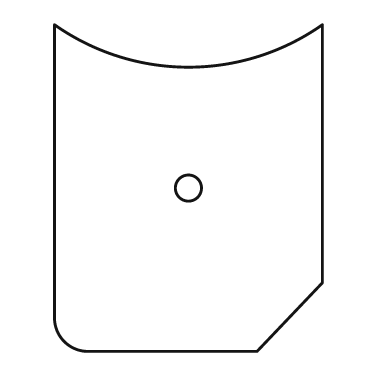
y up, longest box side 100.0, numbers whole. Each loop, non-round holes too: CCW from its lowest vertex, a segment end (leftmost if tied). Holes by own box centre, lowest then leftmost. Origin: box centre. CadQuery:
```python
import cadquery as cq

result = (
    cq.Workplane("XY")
    .moveTo(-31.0, -50.0)
    .lineTo(21.0, -50.0)
    .lineTo(41.0, -29.0)
    .lineTo(41.0, 50.0)
    .threePointArc((0.0, 37.0), (-41.0, 50.0))
    .lineTo(-41.0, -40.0)
    .threePointArc((-38.0, -47.0), (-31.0, -50.0))
    .close()
    .moveTo(0.0, 0.0)
    .circle(4.0)
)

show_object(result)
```